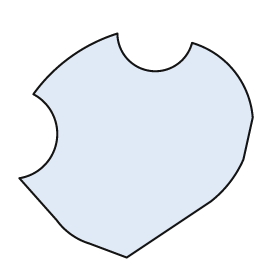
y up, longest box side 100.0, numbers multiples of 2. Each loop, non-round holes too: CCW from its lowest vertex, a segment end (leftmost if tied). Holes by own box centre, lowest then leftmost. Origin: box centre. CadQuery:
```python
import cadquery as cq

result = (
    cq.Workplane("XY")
    .moveTo(-4.0, -48.0)
    .lineTo(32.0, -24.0)
    .threePointArc((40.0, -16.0), (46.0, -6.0))
    .lineTo(50.0, 12.0)
    .threePointArc((42.0, 32.0), (24.0, 44.0))
    .threePointArc((6.0, 32.0), (-8.0, 48.0))
    .threePointArc((-28.0, 38.0), (-44.0, 22.0))
    .threePointArc((-34.0, 2.0), (-50.0, -14.0))
    .lineTo(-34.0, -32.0)
    .threePointArc((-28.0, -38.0), (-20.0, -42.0))
    .close()
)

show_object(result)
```